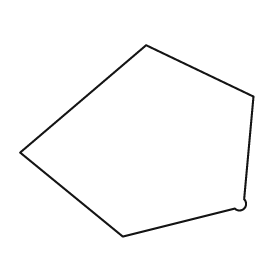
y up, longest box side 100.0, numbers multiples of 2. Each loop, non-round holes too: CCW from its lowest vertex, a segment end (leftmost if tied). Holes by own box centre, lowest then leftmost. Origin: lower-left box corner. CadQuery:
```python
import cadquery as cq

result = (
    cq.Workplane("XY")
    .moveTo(44.0, 0.0)
    .lineTo(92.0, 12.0)
    .threePointArc((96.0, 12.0), (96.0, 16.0))
    .lineTo(100.0, 60.0)
    .lineTo(54.0, 82.0)
    .lineTo(0.0, 36.0)
    .close()
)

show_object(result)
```